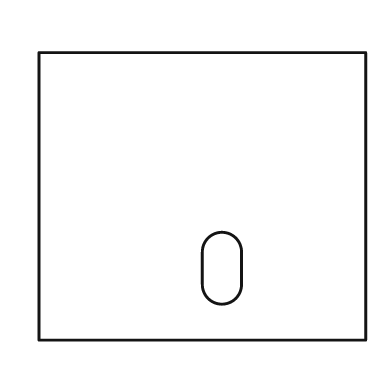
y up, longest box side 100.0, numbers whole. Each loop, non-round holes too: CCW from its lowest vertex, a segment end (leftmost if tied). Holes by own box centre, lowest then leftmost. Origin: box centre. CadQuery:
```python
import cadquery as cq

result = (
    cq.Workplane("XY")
    .moveTo(-50.0, -44.0)
    .lineTo(50.0, -44.0)
    .lineTo(50.0, 44.0)
    .lineTo(-50.0, 44.0)
    .close()
    .moveTo(0.0, -27.0)
    .threePointArc((6.0, -33.0), (12.0, -27.0))
    .lineTo(12.0, -17.0)
    .threePointArc((6.0, -11.0), (0.0, -17.0))
    .close()
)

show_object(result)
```